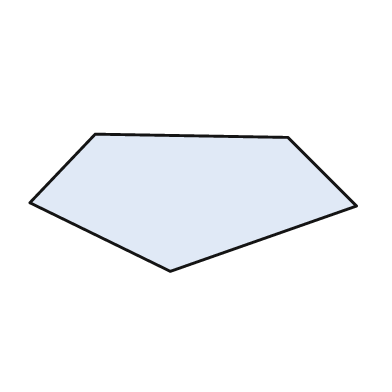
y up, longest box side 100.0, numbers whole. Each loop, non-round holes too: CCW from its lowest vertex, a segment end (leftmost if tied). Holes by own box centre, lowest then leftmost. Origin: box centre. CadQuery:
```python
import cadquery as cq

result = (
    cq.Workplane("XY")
    .moveTo(-7.0, -21.0)
    .lineTo(50.0, -1.0)
    .lineTo(29.0, 20.0)
    .lineTo(-30.0, 21.0)
    .lineTo(-50.0, 0.0)
    .close()
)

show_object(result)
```